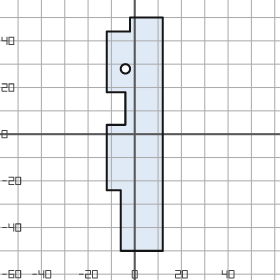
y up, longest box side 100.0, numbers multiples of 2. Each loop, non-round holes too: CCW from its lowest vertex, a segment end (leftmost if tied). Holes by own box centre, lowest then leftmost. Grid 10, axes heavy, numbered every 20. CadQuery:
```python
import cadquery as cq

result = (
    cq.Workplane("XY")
    .moveTo(-6.0, -50.0)
    .lineTo(12.0, -50.0)
    .lineTo(12.0, 50.0)
    .lineTo(-2.0, 50.0)
    .lineTo(-2.0, 44.0)
    .lineTo(-12.0, 44.0)
    .lineTo(-12.0, 18.0)
    .lineTo(-4.0, 18.0)
    .lineTo(-4.0, 4.0)
    .lineTo(-12.0, 4.0)
    .lineTo(-12.0, -24.0)
    .lineTo(-6.0, -24.0)
    .close()
    .moveTo(-4.0, 28.0)
    .circle(2.0)
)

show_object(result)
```